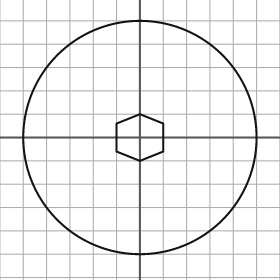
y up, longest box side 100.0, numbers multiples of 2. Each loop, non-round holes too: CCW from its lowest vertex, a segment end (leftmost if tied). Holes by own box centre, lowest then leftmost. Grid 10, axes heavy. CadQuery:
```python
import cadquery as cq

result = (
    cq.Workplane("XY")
    .moveTo(0.0, 0.0)
    .circle(50.0)
    .moveTo(0.0, -10.0)
    .lineTo(10.0, -6.0)
    .lineTo(10.0, 6.0)
    .lineTo(0.0, 10.0)
    .lineTo(-10.0, 6.0)
    .lineTo(-10.0, -6.0)
    .close()
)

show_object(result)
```